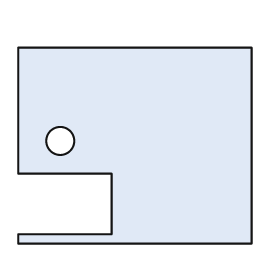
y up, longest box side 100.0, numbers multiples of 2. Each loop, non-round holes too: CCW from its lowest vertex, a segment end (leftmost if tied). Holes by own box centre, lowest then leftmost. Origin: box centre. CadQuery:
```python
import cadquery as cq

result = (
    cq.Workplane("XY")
    .moveTo(-50.0, -42.0)
    .lineTo(50.0, -42.0)
    .lineTo(50.0, 42.0)
    .lineTo(-50.0, 42.0)
    .lineTo(-50.0, -12.0)
    .lineTo(-10.0, -12.0)
    .lineTo(-10.0, -38.0)
    .lineTo(-50.0, -38.0)
    .close()
    .moveTo(-32.0, 2.0)
    .circle(6.0)
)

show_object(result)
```